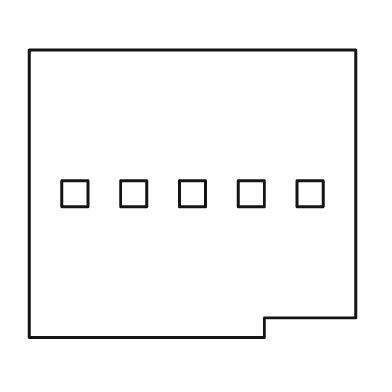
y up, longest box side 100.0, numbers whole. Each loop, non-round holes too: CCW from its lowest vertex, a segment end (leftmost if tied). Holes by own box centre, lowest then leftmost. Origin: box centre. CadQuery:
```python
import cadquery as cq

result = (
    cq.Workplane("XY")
    .moveTo(-50.0, -44.0)
    .lineTo(22.0, -44.0)
    .lineTo(22.0, -38.0)
    .lineTo(50.0, -38.0)
    .lineTo(50.0, 44.0)
    .lineTo(-50.0, 44.0)
    .close()
    .moveTo(-40.0, -4.0)
    .lineTo(-32.0, -4.0)
    .lineTo(-32.0, 4.0)
    .lineTo(-40.0, 4.0)
    .close()
    .moveTo(-22.0, -4.0)
    .lineTo(-14.0, -4.0)
    .lineTo(-14.0, 4.0)
    .lineTo(-22.0, 4.0)
    .close()
    .moveTo(-4.0, -4.0)
    .lineTo(4.0, -4.0)
    .lineTo(4.0, 4.0)
    .lineTo(-4.0, 4.0)
    .close()
    .moveTo(14.0, -4.0)
    .lineTo(22.0, -4.0)
    .lineTo(22.0, 4.0)
    .lineTo(14.0, 4.0)
    .close()
    .moveTo(32.0, -4.0)
    .lineTo(40.0, -4.0)
    .lineTo(40.0, 4.0)
    .lineTo(32.0, 4.0)
    .close()
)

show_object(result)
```